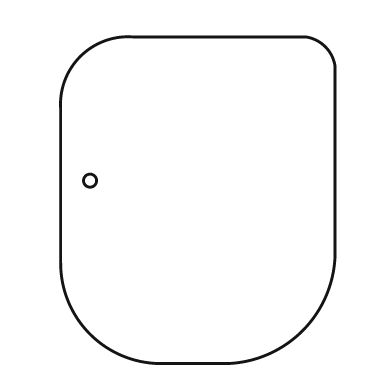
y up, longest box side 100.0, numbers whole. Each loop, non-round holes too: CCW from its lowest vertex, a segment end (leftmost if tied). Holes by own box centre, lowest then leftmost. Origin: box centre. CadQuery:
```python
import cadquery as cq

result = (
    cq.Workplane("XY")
    .moveTo(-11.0, -50.0)
    .lineTo(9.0, -50.0)
    .threePointArc((32.0, -40.0), (42.0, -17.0))
    .lineTo(42.0, 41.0)
    .threePointArc((39.0, 47.0), (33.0, 50.0))
    .lineTo(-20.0, 50.0)
    .threePointArc((-36.0, 44.0), (-42.0, 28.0))
    .lineTo(-42.0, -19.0)
    .threePointArc((-33.0, -41.0), (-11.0, -50.0))
    .close()
    .moveTo(-33.0, 6.0)
    .circle(2.0)
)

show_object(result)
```